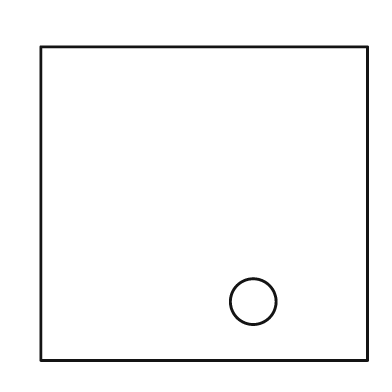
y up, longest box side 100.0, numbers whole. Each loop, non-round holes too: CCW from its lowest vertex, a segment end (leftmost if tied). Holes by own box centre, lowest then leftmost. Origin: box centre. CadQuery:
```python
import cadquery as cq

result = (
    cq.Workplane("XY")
    .moveTo(-50.0, -48.0)
    .lineTo(50.0, -48.0)
    .lineTo(50.0, 48.0)
    .lineTo(-50.0, 48.0)
    .close()
    .moveTo(15.0, -30.0)
    .circle(7.0)
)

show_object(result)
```